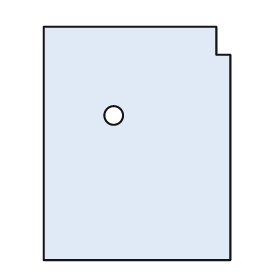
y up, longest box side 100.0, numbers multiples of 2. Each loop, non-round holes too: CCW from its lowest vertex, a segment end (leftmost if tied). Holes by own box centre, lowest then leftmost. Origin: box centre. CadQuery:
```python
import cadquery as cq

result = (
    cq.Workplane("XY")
    .moveTo(-40.0, -50.0)
    .lineTo(40.0, -50.0)
    .lineTo(40.0, 38.0)
    .lineTo(34.0, 38.0)
    .lineTo(34.0, 50.0)
    .lineTo(-40.0, 50.0)
    .close()
    .moveTo(-10.0, 12.0)
    .circle(4.0)
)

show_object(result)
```